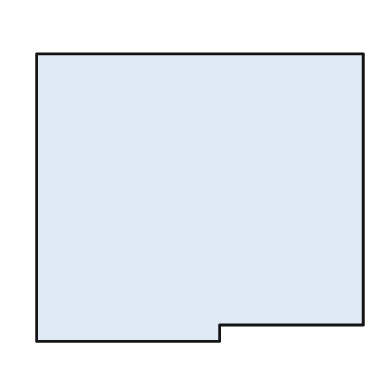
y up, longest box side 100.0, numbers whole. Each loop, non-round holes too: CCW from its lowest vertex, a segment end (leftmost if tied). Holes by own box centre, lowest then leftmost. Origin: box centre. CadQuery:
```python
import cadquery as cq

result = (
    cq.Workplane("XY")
    .moveTo(-50.0, -44.0)
    .lineTo(6.0, -44.0)
    .lineTo(6.0, -39.0)
    .lineTo(50.0, -39.0)
    .lineTo(50.0, 44.0)
    .lineTo(-50.0, 44.0)
    .close()
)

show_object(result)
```